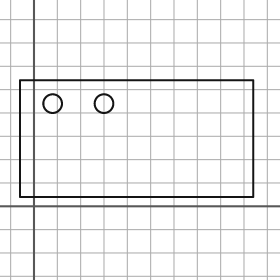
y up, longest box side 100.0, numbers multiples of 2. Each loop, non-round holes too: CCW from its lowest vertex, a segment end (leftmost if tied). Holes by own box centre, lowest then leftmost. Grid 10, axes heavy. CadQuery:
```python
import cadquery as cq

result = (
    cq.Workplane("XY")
    .moveTo(-6.0, 4.0)
    .lineTo(94.0, 4.0)
    .lineTo(94.0, 54.0)
    .lineTo(-6.0, 54.0)
    .close()
    .moveTo(8.0, 44.0)
    .circle(4.0)
    .moveTo(30.0, 44.0)
    .circle(4.0)
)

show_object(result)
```